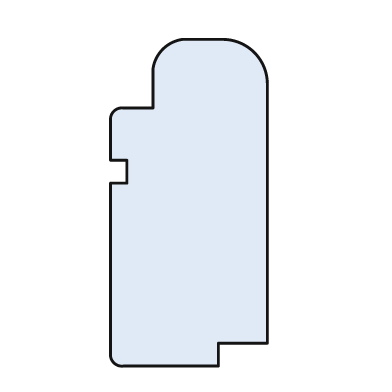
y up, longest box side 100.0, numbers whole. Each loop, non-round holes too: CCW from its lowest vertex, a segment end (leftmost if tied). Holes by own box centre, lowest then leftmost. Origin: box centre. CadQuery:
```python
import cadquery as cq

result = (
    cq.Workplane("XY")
    .moveTo(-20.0, -50.0)
    .lineTo(9.0, -50.0)
    .lineTo(9.0, -43.0)
    .lineTo(24.0, -43.0)
    .lineTo(24.0, 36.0)
    .threePointArc((20.0, 46.0), (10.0, 50.0))
    .lineTo(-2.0, 50.0)
    .threePointArc((-8.0, 47.0), (-11.0, 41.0))
    .lineTo(-11.0, 29.0)
    .lineTo(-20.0, 29.0)
    .threePointArc((-23.0, 28.0), (-24.0, 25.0))
    .lineTo(-24.0, 13.0)
    .lineTo(-19.0, 13.0)
    .lineTo(-19.0, 6.0)
    .lineTo(-24.0, 6.0)
    .lineTo(-24.0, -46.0)
    .threePointArc((-23.0, -49.0), (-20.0, -50.0))
    .close()
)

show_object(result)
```